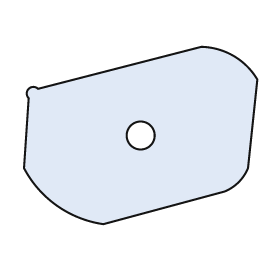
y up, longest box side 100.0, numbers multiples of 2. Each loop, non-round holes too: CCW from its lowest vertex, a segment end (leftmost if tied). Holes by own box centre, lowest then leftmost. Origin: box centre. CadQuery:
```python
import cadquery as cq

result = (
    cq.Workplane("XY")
    .moveTo(-16.0, -38.0)
    .lineTo(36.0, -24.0)
    .threePointArc((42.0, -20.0), (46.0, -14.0))
    .lineTo(50.0, 24.0)
    .threePointArc((40.0, 34.0), (26.0, 38.0))
    .lineTo(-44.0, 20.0)
    .threePointArc((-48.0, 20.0), (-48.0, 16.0))
    .lineTo(-50.0, -14.0)
    .threePointArc((-36.0, -30.0), (-16.0, -38.0))
    .close()
    .moveTo(0.0, 0.0)
    .circle(6.0)
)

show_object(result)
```